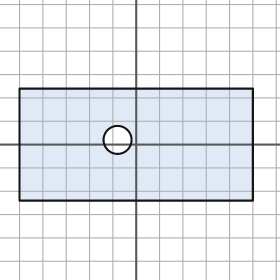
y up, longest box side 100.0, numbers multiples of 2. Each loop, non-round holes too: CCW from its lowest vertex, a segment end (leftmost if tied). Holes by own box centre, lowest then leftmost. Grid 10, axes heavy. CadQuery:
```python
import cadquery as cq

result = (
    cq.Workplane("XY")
    .moveTo(-50.0, -24.0)
    .lineTo(50.0, -24.0)
    .lineTo(50.0, 24.0)
    .lineTo(-50.0, 24.0)
    .close()
    .moveTo(-8.0, 2.0)
    .circle(6.0)
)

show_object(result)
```